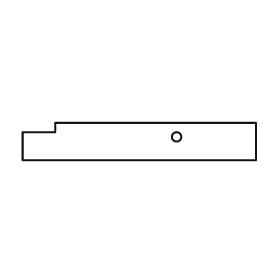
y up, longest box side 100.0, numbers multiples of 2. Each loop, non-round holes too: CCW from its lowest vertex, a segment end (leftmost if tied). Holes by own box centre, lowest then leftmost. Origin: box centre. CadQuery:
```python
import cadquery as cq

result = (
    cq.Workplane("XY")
    .moveTo(-50.0, -8.0)
    .lineTo(50.0, -8.0)
    .lineTo(50.0, 8.0)
    .lineTo(-36.0, 8.0)
    .lineTo(-36.0, 4.0)
    .lineTo(-50.0, 4.0)
    .close()
    .moveTo(16.0, 2.0)
    .circle(2.0)
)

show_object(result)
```